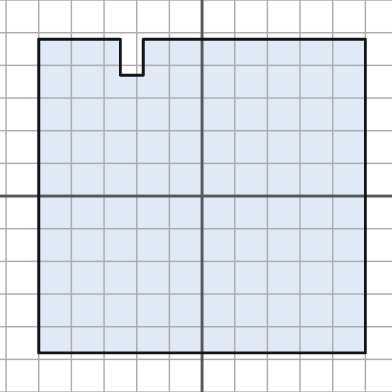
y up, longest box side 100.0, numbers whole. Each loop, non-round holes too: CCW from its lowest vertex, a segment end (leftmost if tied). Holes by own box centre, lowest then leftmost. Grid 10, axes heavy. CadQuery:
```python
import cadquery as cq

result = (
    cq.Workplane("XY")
    .moveTo(-50.0, -48.0)
    .lineTo(50.0, -48.0)
    .lineTo(50.0, 48.0)
    .lineTo(-18.0, 48.0)
    .lineTo(-18.0, 37.0)
    .lineTo(-25.0, 37.0)
    .lineTo(-25.0, 48.0)
    .lineTo(-50.0, 48.0)
    .close()
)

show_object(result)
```